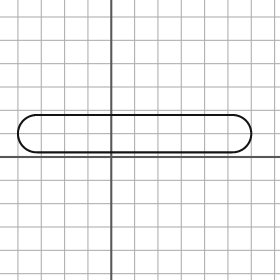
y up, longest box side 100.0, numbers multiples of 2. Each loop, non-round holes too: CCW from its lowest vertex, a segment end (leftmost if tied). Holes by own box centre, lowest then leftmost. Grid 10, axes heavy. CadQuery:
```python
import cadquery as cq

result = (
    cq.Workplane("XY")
    .moveTo(-32.0, 2.0)
    .lineTo(52.0, 2.0)
    .threePointArc((60.0, 10.0), (52.0, 18.0))
    .lineTo(-32.0, 18.0)
    .threePointArc((-40.0, 10.0), (-32.0, 2.0))
    .close()
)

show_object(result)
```